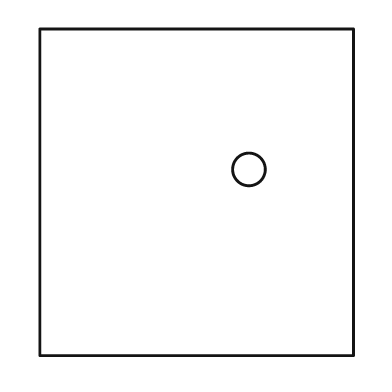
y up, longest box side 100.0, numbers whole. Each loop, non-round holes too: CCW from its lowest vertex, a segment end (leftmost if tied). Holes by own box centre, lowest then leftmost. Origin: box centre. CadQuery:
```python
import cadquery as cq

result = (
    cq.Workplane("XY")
    .moveTo(-48.0, -50.0)
    .lineTo(48.0, -50.0)
    .lineTo(48.0, 50.0)
    .lineTo(-48.0, 50.0)
    .close()
    .moveTo(16.0, 7.0)
    .circle(5.0)
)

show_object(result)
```